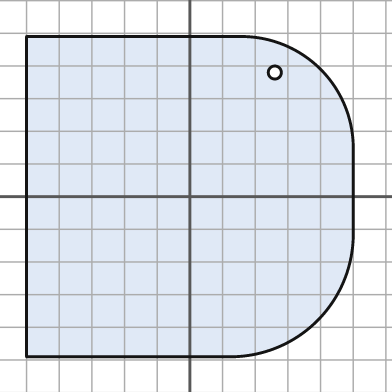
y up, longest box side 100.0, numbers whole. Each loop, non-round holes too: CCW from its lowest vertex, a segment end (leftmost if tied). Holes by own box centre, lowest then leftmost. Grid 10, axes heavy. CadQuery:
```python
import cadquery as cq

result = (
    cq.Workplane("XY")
    .moveTo(-50.0, -49.0)
    .lineTo(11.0, -49.0)
    .threePointArc((39.0, -38.0), (50.0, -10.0))
    .lineTo(50.0, 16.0)
    .threePointArc((40.0, 39.0), (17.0, 49.0))
    .lineTo(-50.0, 49.0)
    .close()
    .moveTo(26.0, 38.0)
    .circle(2.0)
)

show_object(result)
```